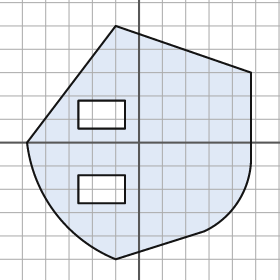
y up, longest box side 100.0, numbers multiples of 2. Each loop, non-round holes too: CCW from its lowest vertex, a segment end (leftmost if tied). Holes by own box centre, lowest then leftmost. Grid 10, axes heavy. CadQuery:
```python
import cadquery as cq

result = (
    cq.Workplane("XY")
    .moveTo(-10.0, -50.0)
    .lineTo(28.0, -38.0)
    .threePointArc((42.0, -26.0), (48.0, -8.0))
    .lineTo(48.0, 30.0)
    .lineTo(-10.0, 50.0)
    .lineTo(-48.0, 0.0)
    .threePointArc((-36.0, -30.0), (-10.0, -50.0))
    .close()
    .moveTo(-26.0, -26.0)
    .lineTo(-6.0, -26.0)
    .lineTo(-6.0, -14.0)
    .lineTo(-26.0, -14.0)
    .close()
    .moveTo(-26.0, 6.0)
    .lineTo(-6.0, 6.0)
    .lineTo(-6.0, 18.0)
    .lineTo(-26.0, 18.0)
    .close()
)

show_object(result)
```